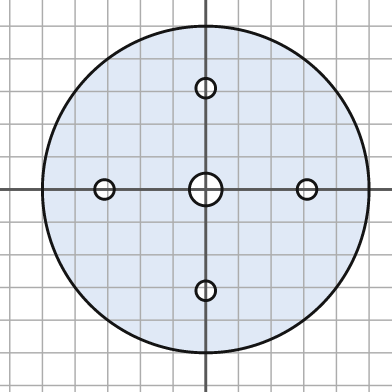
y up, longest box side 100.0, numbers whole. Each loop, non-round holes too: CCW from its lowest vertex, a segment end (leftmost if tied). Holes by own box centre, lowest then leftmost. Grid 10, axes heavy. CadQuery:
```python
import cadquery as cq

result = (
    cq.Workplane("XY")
    .moveTo(0.0, 0.0)
    .circle(50.0)
    .moveTo(0.0, -31.0)
    .circle(3.0)
    .moveTo(-31.0, 0.0)
    .circle(3.0)
    .moveTo(0.0, 0.0)
    .circle(5.0)
    .moveTo(31.0, 0.0)
    .circle(3.0)
    .moveTo(0.0, 31.0)
    .circle(3.0)
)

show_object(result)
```